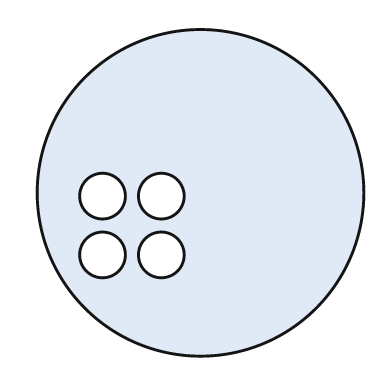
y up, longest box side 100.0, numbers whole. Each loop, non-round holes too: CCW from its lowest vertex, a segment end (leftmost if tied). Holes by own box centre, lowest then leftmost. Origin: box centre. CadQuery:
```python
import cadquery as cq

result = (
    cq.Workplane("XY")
    .moveTo(0.0, 0.0)
    .circle(50.0)
    .moveTo(-30.0, -19.0)
    .circle(7.0)
    .moveTo(-12.0, -19.0)
    .circle(7.0)
    .moveTo(-30.0, -1.0)
    .circle(7.0)
    .moveTo(-12.0, -1.0)
    .circle(7.0)
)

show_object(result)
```